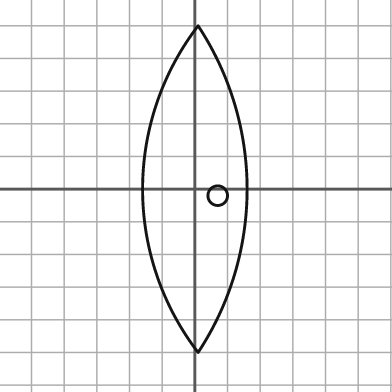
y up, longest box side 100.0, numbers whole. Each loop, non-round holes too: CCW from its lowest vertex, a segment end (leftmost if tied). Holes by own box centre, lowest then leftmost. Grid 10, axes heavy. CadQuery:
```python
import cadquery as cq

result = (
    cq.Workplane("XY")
    .moveTo(1.0, -50.0)
    .threePointArc((16.0, 0.0), (1.0, 50.0))
    .threePointArc((-16.0, 0.0), (1.0, -50.0))
    .close()
    .moveTo(7.0, -2.0)
    .circle(3.0)
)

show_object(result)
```